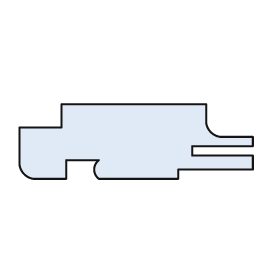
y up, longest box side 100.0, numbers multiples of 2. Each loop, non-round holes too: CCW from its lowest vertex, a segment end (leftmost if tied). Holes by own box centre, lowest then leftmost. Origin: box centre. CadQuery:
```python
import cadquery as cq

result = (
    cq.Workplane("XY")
    .moveTo(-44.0, -16.0)
    .lineTo(-30.0, -16.0)
    .lineTo(-30.0, -8.0)
    .lineTo(-16.0, -8.0)
    .threePointArc((-18.0, -12.0), (-16.0, -16.0))
    .lineTo(18.0, -16.0)
    .lineTo(18.0, -12.0)
    .lineTo(50.0, -12.0)
    .lineTo(50.0, -6.0)
    .lineTo(24.0, -6.0)
    .lineTo(24.0, -2.0)
    .lineTo(50.0, -2.0)
    .lineTo(50.0, 2.0)
    .lineTo(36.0, 2.0)
    .threePointArc((32.0, 4.0), (30.0, 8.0))
    .lineTo(30.0, 16.0)
    .lineTo(-32.0, 16.0)
    .lineTo(-32.0, 6.0)
    .lineTo(-50.0, 6.0)
    .lineTo(-50.0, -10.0)
    .threePointArc((-48.0, -14.0), (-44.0, -16.0))
    .close()
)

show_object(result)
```